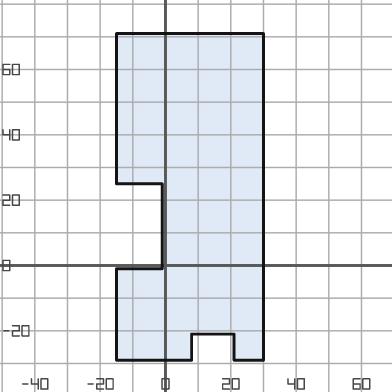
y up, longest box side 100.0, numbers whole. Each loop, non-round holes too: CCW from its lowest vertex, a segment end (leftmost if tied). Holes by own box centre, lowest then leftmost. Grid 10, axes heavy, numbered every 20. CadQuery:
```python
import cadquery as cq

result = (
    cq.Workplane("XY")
    .moveTo(-15.0, -29.0)
    .lineTo(8.0, -29.0)
    .lineTo(8.0, -21.0)
    .lineTo(21.0, -21.0)
    .lineTo(21.0, -29.0)
    .lineTo(30.0, -29.0)
    .lineTo(30.0, 71.0)
    .lineTo(-15.0, 71.0)
    .lineTo(-15.0, 25.0)
    .lineTo(-1.0, 25.0)
    .lineTo(-1.0, -1.0)
    .lineTo(-15.0, -1.0)
    .close()
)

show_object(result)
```